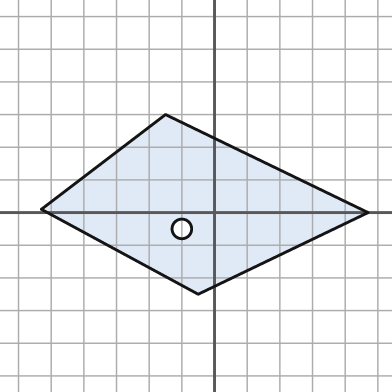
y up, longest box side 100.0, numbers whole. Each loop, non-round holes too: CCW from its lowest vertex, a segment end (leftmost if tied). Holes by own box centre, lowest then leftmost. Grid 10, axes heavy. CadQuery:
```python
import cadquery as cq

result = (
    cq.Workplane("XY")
    .moveTo(-5.0, -25.0)
    .lineTo(47.0, 0.0)
    .lineTo(-15.0, 30.0)
    .lineTo(-53.0, 1.0)
    .close()
    .moveTo(-10.0, -5.0)
    .circle(3.0)
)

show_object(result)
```